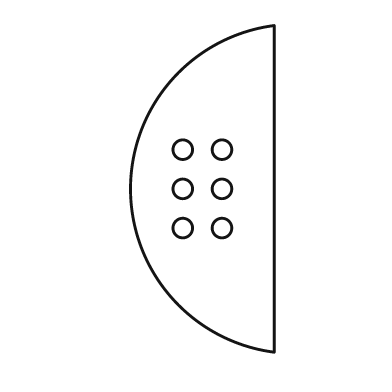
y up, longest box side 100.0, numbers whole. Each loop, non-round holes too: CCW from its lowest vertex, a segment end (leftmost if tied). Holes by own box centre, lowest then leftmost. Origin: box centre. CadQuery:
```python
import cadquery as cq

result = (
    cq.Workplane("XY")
    .moveTo(22.0, -50.0)
    .lineTo(22.0, 50.0)
    .threePointArc((-22.0, 0.0), (22.0, -50.0))
    .close()
    .moveTo(-6.0, -12.0)
    .circle(3.0)
    .moveTo(6.0, -12.0)
    .circle(3.0)
    .moveTo(-6.0, 0.0)
    .circle(3.0)
    .moveTo(6.0, 0.0)
    .circle(3.0)
    .moveTo(-6.0, 12.0)
    .circle(3.0)
    .moveTo(6.0, 12.0)
    .circle(3.0)
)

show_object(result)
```